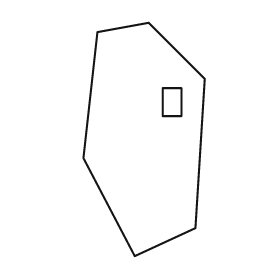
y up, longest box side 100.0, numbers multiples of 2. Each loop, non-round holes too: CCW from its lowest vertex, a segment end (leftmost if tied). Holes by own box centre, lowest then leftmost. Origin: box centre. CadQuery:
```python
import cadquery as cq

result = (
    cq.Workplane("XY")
    .moveTo(-4.0, -50.0)
    .lineTo(22.0, -38.0)
    .lineTo(26.0, 26.0)
    .lineTo(2.0, 50.0)
    .lineTo(-20.0, 46.0)
    .lineTo(-26.0, -8.0)
    .close()
    .moveTo(8.0, 10.0)
    .lineTo(16.0, 10.0)
    .lineTo(16.0, 22.0)
    .lineTo(8.0, 22.0)
    .close()
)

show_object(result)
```